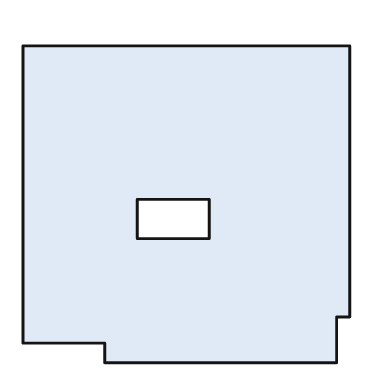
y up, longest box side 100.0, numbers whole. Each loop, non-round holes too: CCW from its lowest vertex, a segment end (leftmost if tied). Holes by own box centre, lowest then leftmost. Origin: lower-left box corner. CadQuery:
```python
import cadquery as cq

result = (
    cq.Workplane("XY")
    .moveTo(25.0, 0.0)
    .lineTo(96.0, 0.0)
    .lineTo(96.0, 14.0)
    .lineTo(100.0, 14.0)
    .lineTo(100.0, 97.0)
    .lineTo(0.0, 97.0)
    .lineTo(0.0, 6.0)
    .lineTo(25.0, 6.0)
    .close()
    .moveTo(35.0, 38.0)
    .lineTo(57.0, 38.0)
    .lineTo(57.0, 50.0)
    .lineTo(35.0, 50.0)
    .close()
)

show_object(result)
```